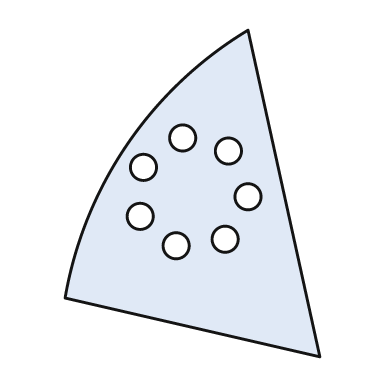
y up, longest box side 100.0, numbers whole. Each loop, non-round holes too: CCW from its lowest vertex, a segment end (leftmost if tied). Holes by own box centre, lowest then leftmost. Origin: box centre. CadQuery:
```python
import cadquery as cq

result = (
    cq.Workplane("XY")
    .moveTo(39.0, -50.0)
    .lineTo(17.0, 50.0)
    .threePointArc((-20.0, 15.0), (-39.0, -32.0))
    .close()
    .moveTo(-5.0, -16.0)
    .circle(4.0)
    .moveTo(10.0, -14.0)
    .circle(4.0)
    .moveTo(-16.0, -7.0)
    .circle(4.0)
    .moveTo(17.0, -1.0)
    .circle(4.0)
    .moveTo(-15.0, 8.0)
    .circle(4.0)
    .moveTo(11.0, 13.0)
    .circle(4.0)
    .moveTo(-3.0, 17.0)
    .circle(4.0)
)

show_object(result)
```